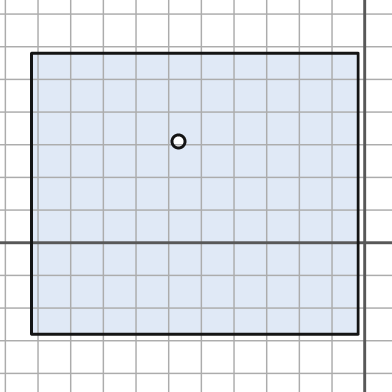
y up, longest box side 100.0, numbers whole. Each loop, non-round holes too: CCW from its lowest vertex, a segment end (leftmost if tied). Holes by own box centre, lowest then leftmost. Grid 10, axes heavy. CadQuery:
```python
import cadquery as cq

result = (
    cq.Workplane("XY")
    .moveTo(-102.0, -28.0)
    .lineTo(-2.0, -28.0)
    .lineTo(-2.0, 58.0)
    .lineTo(-102.0, 58.0)
    .close()
    .moveTo(-57.0, 31.0)
    .circle(2.0)
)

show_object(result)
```